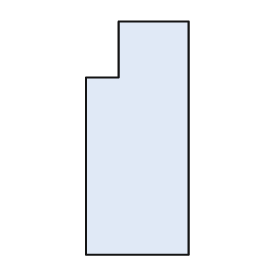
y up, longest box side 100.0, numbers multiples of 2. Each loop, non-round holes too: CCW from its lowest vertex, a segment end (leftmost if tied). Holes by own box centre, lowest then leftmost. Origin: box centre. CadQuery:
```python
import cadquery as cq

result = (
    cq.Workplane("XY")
    .moveTo(-22.0, -50.0)
    .lineTo(22.0, -50.0)
    .lineTo(22.0, 50.0)
    .lineTo(-8.0, 50.0)
    .lineTo(-8.0, 26.0)
    .lineTo(-22.0, 26.0)
    .close()
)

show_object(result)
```